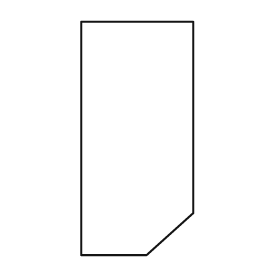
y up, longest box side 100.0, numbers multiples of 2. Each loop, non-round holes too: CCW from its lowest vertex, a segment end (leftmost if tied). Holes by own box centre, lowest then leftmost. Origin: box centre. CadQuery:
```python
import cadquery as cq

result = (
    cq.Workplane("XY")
    .moveTo(-24.0, -50.0)
    .lineTo(4.0, -50.0)
    .lineTo(24.0, -32.0)
    .lineTo(24.0, 50.0)
    .lineTo(-24.0, 50.0)
    .close()
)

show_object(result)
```